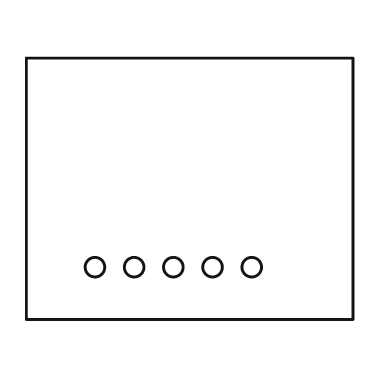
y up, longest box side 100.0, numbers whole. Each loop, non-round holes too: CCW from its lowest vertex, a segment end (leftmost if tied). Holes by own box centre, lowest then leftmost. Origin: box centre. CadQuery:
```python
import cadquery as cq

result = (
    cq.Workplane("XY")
    .moveTo(-50.0, -40.0)
    .lineTo(50.0, -40.0)
    .lineTo(50.0, 40.0)
    .lineTo(-50.0, 40.0)
    .close()
    .moveTo(-29.0, -24.0)
    .circle(3.0)
    .moveTo(-17.0, -24.0)
    .circle(3.0)
    .moveTo(-5.0, -24.0)
    .circle(3.0)
    .moveTo(7.0, -24.0)
    .circle(3.0)
    .moveTo(19.0, -24.0)
    .circle(3.0)
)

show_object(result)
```